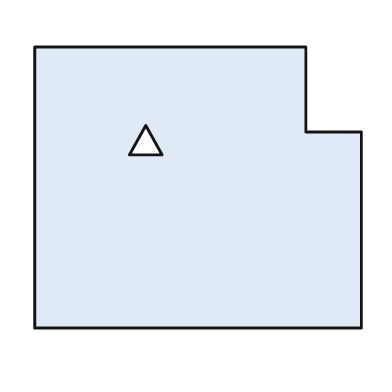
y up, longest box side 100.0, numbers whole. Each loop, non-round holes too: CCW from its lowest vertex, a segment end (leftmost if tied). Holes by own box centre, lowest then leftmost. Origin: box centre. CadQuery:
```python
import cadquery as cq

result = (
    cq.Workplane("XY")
    .moveTo(-50.0, -43.0)
    .lineTo(50.0, -43.0)
    .lineTo(50.0, 17.0)
    .lineTo(33.0, 17.0)
    .lineTo(33.0, 43.0)
    .lineTo(-50.0, 43.0)
    .close()
    .moveTo(-21.0, 10.0)
    .lineTo(-11.0, 10.0)
    .lineTo(-16.0, 19.0)
    .close()
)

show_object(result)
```